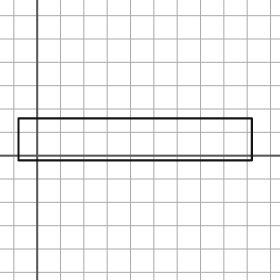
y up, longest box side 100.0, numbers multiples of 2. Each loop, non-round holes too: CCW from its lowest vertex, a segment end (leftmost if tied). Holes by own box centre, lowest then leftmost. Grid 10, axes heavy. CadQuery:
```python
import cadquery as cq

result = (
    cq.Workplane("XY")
    .moveTo(-8.0, -2.0)
    .lineTo(92.0, -2.0)
    .lineTo(92.0, 16.0)
    .lineTo(-8.0, 16.0)
    .close()
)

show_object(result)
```